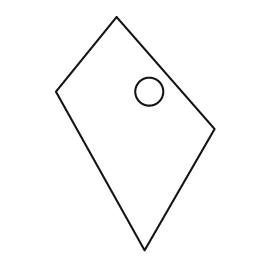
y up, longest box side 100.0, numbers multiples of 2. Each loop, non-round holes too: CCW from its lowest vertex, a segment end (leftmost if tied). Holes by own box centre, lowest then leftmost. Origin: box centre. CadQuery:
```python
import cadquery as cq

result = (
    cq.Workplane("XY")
    .moveTo(4.0, -50.0)
    .lineTo(34.0, 2.0)
    .lineTo(-8.0, 50.0)
    .lineTo(-34.0, 18.0)
    .close()
    .moveTo(6.0, 18.0)
    .circle(6.0)
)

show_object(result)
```